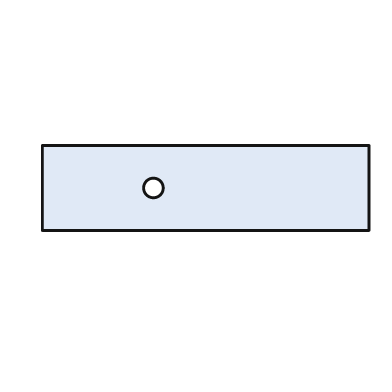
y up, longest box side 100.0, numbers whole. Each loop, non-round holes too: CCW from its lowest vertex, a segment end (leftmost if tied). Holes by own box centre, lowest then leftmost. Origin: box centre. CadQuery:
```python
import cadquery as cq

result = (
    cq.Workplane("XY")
    .moveTo(-50.0, -13.0)
    .lineTo(50.0, -13.0)
    .lineTo(50.0, 13.0)
    .lineTo(-50.0, 13.0)
    .close()
    .moveTo(-16.0, 0.0)
    .circle(3.0)
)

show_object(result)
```